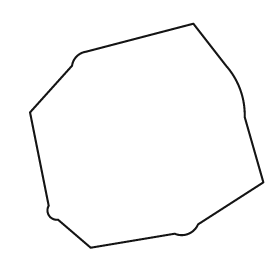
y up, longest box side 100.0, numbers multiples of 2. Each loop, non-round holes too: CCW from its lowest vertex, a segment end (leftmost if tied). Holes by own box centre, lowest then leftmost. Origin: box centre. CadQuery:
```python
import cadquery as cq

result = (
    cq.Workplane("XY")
    .moveTo(-24.0, -48.0)
    .lineTo(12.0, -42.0)
    .threePointArc((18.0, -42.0), (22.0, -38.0))
    .lineTo(50.0, -20.0)
    .lineTo(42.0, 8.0)
    .threePointArc((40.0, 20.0), (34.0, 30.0))
    .lineTo(20.0, 48.0)
    .lineTo(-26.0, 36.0)
    .threePointArc((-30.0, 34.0), (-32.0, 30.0))
    .lineTo(-50.0, 10.0)
    .lineTo(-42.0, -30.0)
    .threePointArc((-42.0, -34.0), (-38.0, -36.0))
    .close()
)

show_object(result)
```